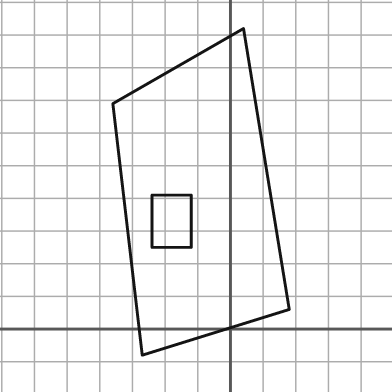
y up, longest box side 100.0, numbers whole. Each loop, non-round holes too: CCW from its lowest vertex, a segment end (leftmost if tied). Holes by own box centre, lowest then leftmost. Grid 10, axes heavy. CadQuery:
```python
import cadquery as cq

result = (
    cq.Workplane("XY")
    .moveTo(-27.0, -8.0)
    .lineTo(18.0, 6.0)
    .lineTo(4.0, 92.0)
    .lineTo(-36.0, 69.0)
    .close()
    .moveTo(-24.0, 25.0)
    .lineTo(-12.0, 25.0)
    .lineTo(-12.0, 41.0)
    .lineTo(-24.0, 41.0)
    .close()
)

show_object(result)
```